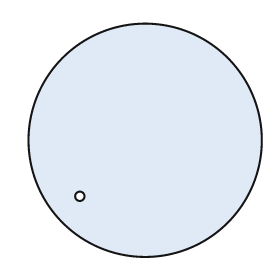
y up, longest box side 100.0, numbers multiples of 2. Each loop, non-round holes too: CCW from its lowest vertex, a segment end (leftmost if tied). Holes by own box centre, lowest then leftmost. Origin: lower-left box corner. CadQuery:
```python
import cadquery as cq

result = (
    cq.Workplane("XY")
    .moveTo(50.0, 50.0)
    .circle(50.0)
    .moveTo(22.0, 26.0)
    .circle(2.0)
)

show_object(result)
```